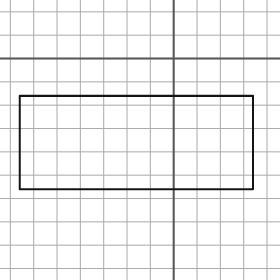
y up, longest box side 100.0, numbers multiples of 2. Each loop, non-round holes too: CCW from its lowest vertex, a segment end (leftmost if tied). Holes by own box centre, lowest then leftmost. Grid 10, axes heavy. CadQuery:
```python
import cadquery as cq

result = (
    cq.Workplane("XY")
    .moveTo(-66.0, -56.0)
    .lineTo(34.0, -56.0)
    .lineTo(34.0, -16.0)
    .lineTo(-66.0, -16.0)
    .close()
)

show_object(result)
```